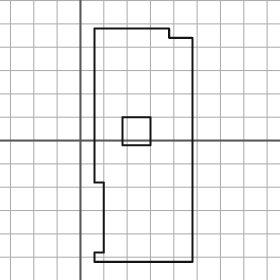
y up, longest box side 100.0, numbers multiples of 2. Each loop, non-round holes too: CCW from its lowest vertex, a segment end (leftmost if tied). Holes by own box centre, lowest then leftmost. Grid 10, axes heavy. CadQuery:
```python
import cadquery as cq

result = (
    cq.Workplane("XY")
    .moveTo(6.0, -52.0)
    .lineTo(48.0, -52.0)
    .lineTo(48.0, 44.0)
    .lineTo(38.0, 44.0)
    .lineTo(38.0, 48.0)
    .lineTo(6.0, 48.0)
    .lineTo(6.0, -18.0)
    .lineTo(10.0, -18.0)
    .lineTo(10.0, -48.0)
    .lineTo(6.0, -48.0)
    .close()
    .moveTo(18.0, -2.0)
    .lineTo(30.0, -2.0)
    .lineTo(30.0, 10.0)
    .lineTo(18.0, 10.0)
    .close()
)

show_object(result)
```